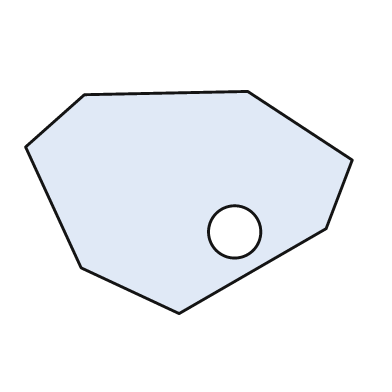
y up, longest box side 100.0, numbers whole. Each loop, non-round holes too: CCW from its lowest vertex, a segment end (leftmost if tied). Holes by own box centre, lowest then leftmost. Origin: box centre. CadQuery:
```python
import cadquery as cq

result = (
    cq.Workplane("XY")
    .moveTo(-3.0, -34.0)
    .lineTo(42.0, -8.0)
    .lineTo(50.0, 13.0)
    .lineTo(18.0, 34.0)
    .lineTo(-32.0, 33.0)
    .lineTo(-50.0, 17.0)
    .lineTo(-33.0, -20.0)
    .close()
    .moveTo(14.0, -9.0)
    .circle(8.0)
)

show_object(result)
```